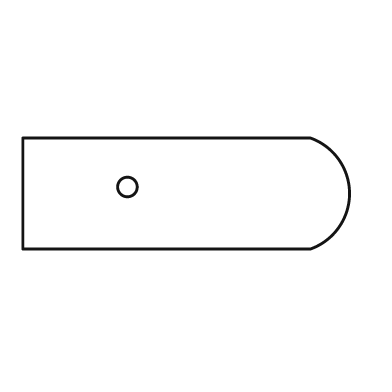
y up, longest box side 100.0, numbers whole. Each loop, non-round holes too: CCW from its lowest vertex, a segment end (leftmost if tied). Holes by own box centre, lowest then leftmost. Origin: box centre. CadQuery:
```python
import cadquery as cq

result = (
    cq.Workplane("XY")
    .moveTo(-50.0, -17.0)
    .lineTo(38.0, -17.0)
    .threePointArc((50.0, 0.0), (38.0, 17.0))
    .lineTo(-50.0, 17.0)
    .close()
    .moveTo(-18.0, 2.0)
    .circle(3.0)
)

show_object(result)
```